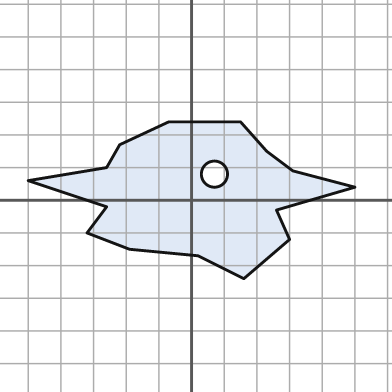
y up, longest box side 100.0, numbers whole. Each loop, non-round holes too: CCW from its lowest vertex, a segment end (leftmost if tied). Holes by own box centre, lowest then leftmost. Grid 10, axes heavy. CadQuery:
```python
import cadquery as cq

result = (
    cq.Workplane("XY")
    .moveTo(16.0, -24.0)
    .lineTo(30.0, -12.0)
    .lineTo(26.0, -3.0)
    .lineTo(50.0, 4.0)
    .lineTo(31.0, 9.0)
    .lineTo(23.0, 15.0)
    .lineTo(15.0, 24.0)
    .lineTo(-7.0, 24.0)
    .lineTo(-22.0, 17.0)
    .lineTo(-26.0, 10.0)
    .lineTo(-50.0, 6.0)
    .lineTo(-26.0, -2.0)
    .lineTo(-32.0, -10.0)
    .lineTo(-19.0, -15.0)
    .lineTo(2.0, -17.0)
    .close()
    .moveTo(7.0, 8.0)
    .circle(4.0)
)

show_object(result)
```